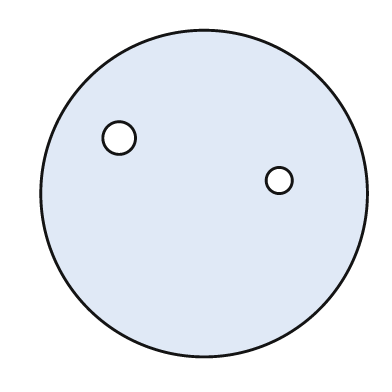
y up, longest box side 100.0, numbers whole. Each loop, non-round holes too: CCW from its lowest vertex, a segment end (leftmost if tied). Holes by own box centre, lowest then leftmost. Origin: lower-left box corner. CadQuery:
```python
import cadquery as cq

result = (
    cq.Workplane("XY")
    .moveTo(50.0, 50.0)
    .circle(50.0)
    .moveTo(73.0, 54.0)
    .circle(4.0)
    .moveTo(24.0, 67.0)
    .circle(5.0)
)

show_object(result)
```